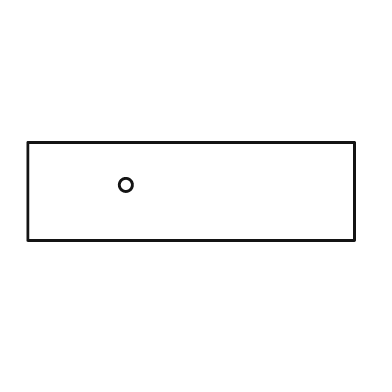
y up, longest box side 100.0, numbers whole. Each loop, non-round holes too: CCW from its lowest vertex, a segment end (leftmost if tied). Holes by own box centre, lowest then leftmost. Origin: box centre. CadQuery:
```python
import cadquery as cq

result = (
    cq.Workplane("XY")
    .moveTo(-50.0, -15.0)
    .lineTo(50.0, -15.0)
    .lineTo(50.0, 15.0)
    .lineTo(-50.0, 15.0)
    .close()
    .moveTo(-20.0, 2.0)
    .circle(2.0)
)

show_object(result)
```